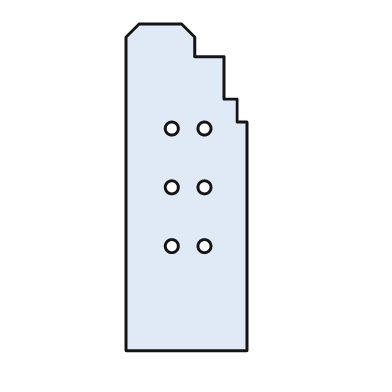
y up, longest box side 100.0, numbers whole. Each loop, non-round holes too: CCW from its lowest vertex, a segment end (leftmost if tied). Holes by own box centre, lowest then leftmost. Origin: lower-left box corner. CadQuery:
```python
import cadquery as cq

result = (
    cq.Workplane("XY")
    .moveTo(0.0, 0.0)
    .lineTo(37.0, 0.0)
    .lineTo(37.0, 70.0)
    .lineTo(34.0, 70.0)
    .lineTo(34.0, 77.0)
    .lineTo(30.0, 77.0)
    .lineTo(30.0, 90.0)
    .lineTo(21.0, 90.0)
    .lineTo(21.0, 96.0)
    .lineTo(17.0, 100.0)
    .lineTo(4.0, 100.0)
    .lineTo(0.0, 96.0)
    .close()
    .moveTo(14.0, 32.0)
    .circle(2.0)
    .moveTo(24.0, 32.0)
    .circle(2.0)
    .moveTo(14.0, 50.0)
    .circle(2.0)
    .moveTo(24.0, 50.0)
    .circle(2.0)
    .moveTo(14.0, 68.0)
    .circle(2.0)
    .moveTo(24.0, 68.0)
    .circle(2.0)
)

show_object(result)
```